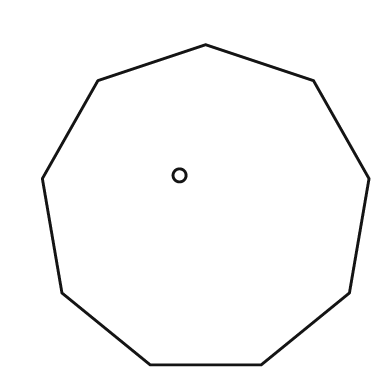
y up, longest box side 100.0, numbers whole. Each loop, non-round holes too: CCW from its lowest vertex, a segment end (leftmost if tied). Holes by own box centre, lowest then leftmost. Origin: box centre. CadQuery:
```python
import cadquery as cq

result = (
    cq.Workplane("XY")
    .moveTo(-17.0, -49.0)
    .lineTo(17.0, -49.0)
    .lineTo(44.0, -27.0)
    .lineTo(50.0, 8.0)
    .lineTo(33.0, 38.0)
    .lineTo(0.0, 49.0)
    .lineTo(-33.0, 38.0)
    .lineTo(-50.0, 8.0)
    .lineTo(-44.0, -27.0)
    .close()
    .moveTo(-8.0, 9.0)
    .circle(2.0)
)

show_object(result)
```